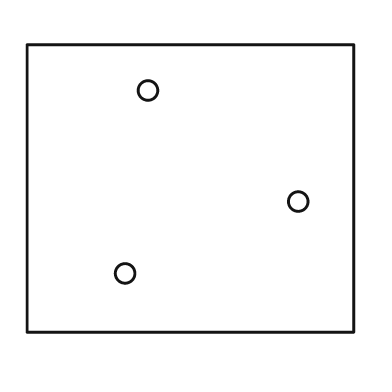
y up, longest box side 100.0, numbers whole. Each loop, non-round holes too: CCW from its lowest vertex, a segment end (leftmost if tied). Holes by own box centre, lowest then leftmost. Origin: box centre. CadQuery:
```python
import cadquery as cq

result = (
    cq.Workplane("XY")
    .moveTo(-50.0, -44.0)
    .lineTo(50.0, -44.0)
    .lineTo(50.0, 44.0)
    .lineTo(-50.0, 44.0)
    .close()
    .moveTo(-20.0, -26.0)
    .circle(3.0)
    .moveTo(33.0, -4.0)
    .circle(3.0)
    .moveTo(-13.0, 30.0)
    .circle(3.0)
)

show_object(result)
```